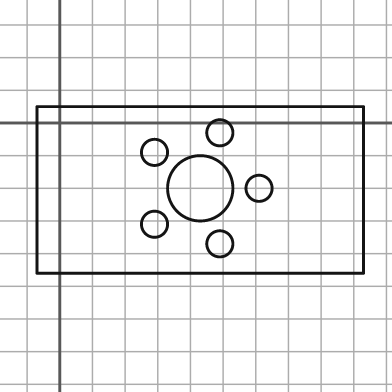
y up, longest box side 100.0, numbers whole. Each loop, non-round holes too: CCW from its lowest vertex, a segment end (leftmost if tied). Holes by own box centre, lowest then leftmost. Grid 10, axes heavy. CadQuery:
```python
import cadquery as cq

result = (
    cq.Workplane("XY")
    .moveTo(-7.0, -46.0)
    .lineTo(93.0, -46.0)
    .lineTo(93.0, 5.0)
    .lineTo(-7.0, 5.0)
    .close()
    .moveTo(49.0, -37.0)
    .circle(4.0)
    .moveTo(29.0, -31.0)
    .circle(4.0)
    .moveTo(43.0, -20.0)
    .circle(10.0)
    .moveTo(61.0, -20.0)
    .circle(4.0)
    .moveTo(29.0, -9.0)
    .circle(4.0)
    .moveTo(49.0, -3.0)
    .circle(4.0)
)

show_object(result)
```